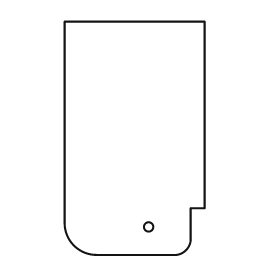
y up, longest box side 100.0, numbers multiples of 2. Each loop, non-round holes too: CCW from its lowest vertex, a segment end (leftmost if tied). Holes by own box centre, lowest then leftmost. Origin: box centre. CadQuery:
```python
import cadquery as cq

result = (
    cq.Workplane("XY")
    .moveTo(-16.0, -50.0)
    .lineTo(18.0, -50.0)
    .threePointArc((22.0, -48.0), (24.0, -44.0))
    .lineTo(24.0, -30.0)
    .lineTo(30.0, -30.0)
    .lineTo(30.0, 50.0)
    .lineTo(-30.0, 50.0)
    .lineTo(-30.0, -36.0)
    .threePointArc((-26.0, -46.0), (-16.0, -50.0))
    .close()
    .moveTo(6.0, -38.0)
    .circle(2.0)
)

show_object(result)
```